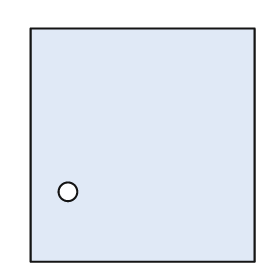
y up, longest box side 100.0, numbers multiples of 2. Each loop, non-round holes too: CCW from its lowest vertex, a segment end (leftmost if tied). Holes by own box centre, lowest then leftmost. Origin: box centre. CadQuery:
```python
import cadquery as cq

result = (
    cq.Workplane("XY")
    .moveTo(-48.0, -50.0)
    .lineTo(48.0, -50.0)
    .lineTo(48.0, 50.0)
    .lineTo(-48.0, 50.0)
    .close()
    .moveTo(-32.0, -20.0)
    .circle(4.0)
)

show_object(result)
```